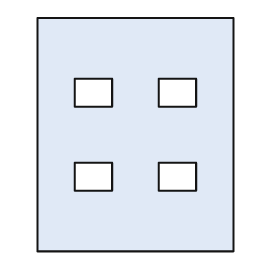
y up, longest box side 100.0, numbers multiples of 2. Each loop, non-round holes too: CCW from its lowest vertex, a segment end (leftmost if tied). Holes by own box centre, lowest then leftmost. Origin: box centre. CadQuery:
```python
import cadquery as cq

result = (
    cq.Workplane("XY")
    .moveTo(-42.0, -50.0)
    .lineTo(42.0, -50.0)
    .lineTo(42.0, 50.0)
    .lineTo(-42.0, 50.0)
    .close()
    .moveTo(-26.0, -24.0)
    .lineTo(-10.0, -24.0)
    .lineTo(-10.0, -12.0)
    .lineTo(-26.0, -12.0)
    .close()
    .moveTo(10.0, -24.0)
    .lineTo(26.0, -24.0)
    .lineTo(26.0, -12.0)
    .lineTo(10.0, -12.0)
    .close()
    .moveTo(-26.0, 12.0)
    .lineTo(-10.0, 12.0)
    .lineTo(-10.0, 24.0)
    .lineTo(-26.0, 24.0)
    .close()
    .moveTo(10.0, 12.0)
    .lineTo(26.0, 12.0)
    .lineTo(26.0, 24.0)
    .lineTo(10.0, 24.0)
    .close()
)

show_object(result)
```